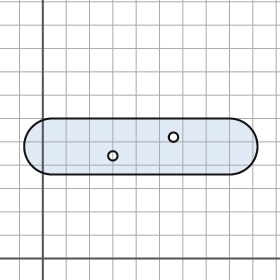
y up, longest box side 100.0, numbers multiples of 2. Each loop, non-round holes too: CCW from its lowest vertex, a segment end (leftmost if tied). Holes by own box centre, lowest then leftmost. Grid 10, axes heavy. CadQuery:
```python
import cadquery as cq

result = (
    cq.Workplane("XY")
    .moveTo(4.0, 36.0)
    .lineTo(80.0, 36.0)
    .threePointArc((92.0, 48.0), (80.0, 60.0))
    .lineTo(4.0, 60.0)
    .threePointArc((-8.0, 48.0), (4.0, 36.0))
    .close()
    .moveTo(30.0, 44.0)
    .circle(2.0)
    .moveTo(56.0, 52.0)
    .circle(2.0)
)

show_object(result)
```